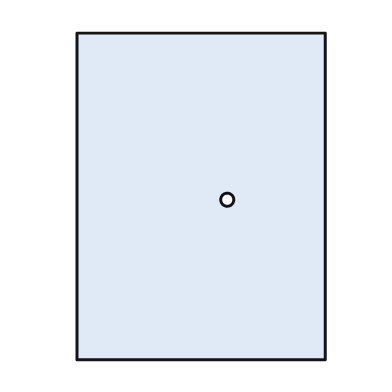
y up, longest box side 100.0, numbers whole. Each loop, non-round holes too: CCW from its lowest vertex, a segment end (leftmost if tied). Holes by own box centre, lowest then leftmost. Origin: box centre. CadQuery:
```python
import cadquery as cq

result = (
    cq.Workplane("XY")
    .moveTo(-38.0, -50.0)
    .lineTo(38.0, -50.0)
    .lineTo(38.0, 50.0)
    .lineTo(-38.0, 50.0)
    .close()
    .moveTo(8.0, -1.0)
    .circle(2.0)
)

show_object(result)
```